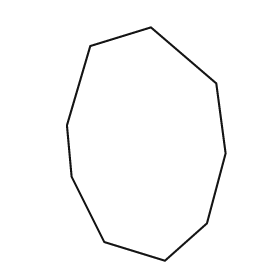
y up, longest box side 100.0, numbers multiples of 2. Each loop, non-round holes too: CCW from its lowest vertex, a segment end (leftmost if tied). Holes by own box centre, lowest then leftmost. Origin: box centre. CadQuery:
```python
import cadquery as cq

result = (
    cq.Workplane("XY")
    .moveTo(8.0, -50.0)
    .lineTo(26.0, -34.0)
    .lineTo(34.0, -4.0)
    .lineTo(30.0, 26.0)
    .lineTo(2.0, 50.0)
    .lineTo(-24.0, 42.0)
    .lineTo(-34.0, 8.0)
    .lineTo(-32.0, -14.0)
    .lineTo(-18.0, -42.0)
    .close()
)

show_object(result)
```